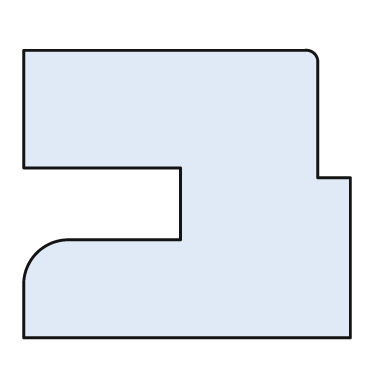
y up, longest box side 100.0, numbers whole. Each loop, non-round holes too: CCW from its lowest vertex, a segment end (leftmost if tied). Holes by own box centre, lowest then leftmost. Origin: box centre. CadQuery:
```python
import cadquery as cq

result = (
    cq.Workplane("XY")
    .moveTo(-50.0, -44.0)
    .lineTo(50.0, -44.0)
    .lineTo(50.0, 5.0)
    .lineTo(40.0, 5.0)
    .lineTo(40.0, 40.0)
    .threePointArc((39.0, 43.0), (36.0, 44.0))
    .lineTo(-50.0, 44.0)
    .lineTo(-50.0, 8.0)
    .lineTo(-2.0, 8.0)
    .lineTo(-2.0, -14.0)
    .lineTo(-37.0, -14.0)
    .threePointArc((-46.0, -18.0), (-50.0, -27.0))
    .close()
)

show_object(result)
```